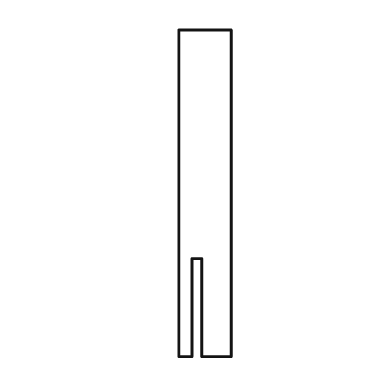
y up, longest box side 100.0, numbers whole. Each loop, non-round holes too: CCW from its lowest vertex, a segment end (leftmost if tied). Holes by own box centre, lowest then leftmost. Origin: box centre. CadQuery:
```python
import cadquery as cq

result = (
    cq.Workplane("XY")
    .moveTo(-8.0, -50.0)
    .lineTo(-4.0, -50.0)
    .lineTo(-4.0, -20.0)
    .lineTo(-1.0, -20.0)
    .lineTo(-1.0, -50.0)
    .lineTo(8.0, -50.0)
    .lineTo(8.0, 50.0)
    .lineTo(-8.0, 50.0)
    .close()
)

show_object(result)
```